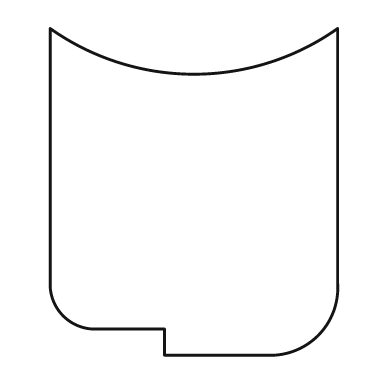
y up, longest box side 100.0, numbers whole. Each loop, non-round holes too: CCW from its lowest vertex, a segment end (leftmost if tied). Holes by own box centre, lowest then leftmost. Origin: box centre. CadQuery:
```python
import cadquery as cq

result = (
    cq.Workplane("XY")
    .moveTo(-9.0, -50.0)
    .lineTo(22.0, -50.0)
    .threePointArc((38.0, -44.0), (44.0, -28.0))
    .lineTo(44.0, 50.0)
    .threePointArc((0.0, 36.0), (-44.0, 50.0))
    .lineTo(-44.0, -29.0)
    .threePointArc((-40.0, -38.0), (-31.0, -42.0))
    .lineTo(-9.0, -42.0)
    .close()
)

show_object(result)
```